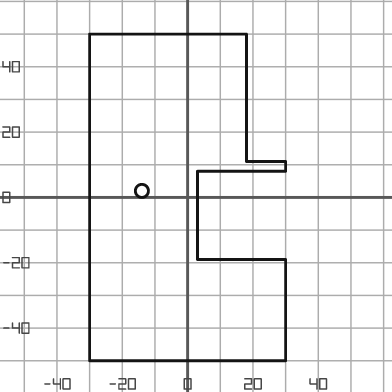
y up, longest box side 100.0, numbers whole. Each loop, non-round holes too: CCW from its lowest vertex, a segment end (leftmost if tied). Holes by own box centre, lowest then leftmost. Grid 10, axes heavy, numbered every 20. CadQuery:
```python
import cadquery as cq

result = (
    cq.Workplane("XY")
    .moveTo(-30.0, -50.0)
    .lineTo(30.0, -50.0)
    .lineTo(30.0, -19.0)
    .lineTo(3.0, -19.0)
    .lineTo(3.0, 8.0)
    .lineTo(30.0, 8.0)
    .lineTo(30.0, 11.0)
    .lineTo(18.0, 11.0)
    .lineTo(18.0, 50.0)
    .lineTo(-30.0, 50.0)
    .close()
    .moveTo(-14.0, 2.0)
    .circle(2.0)
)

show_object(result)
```